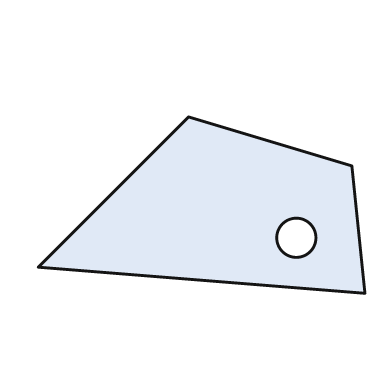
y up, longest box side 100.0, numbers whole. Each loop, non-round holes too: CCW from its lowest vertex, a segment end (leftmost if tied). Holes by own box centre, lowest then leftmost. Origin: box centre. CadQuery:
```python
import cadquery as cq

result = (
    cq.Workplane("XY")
    .moveTo(50.0, -27.0)
    .lineTo(46.0, 12.0)
    .lineTo(-4.0, 27.0)
    .lineTo(-50.0, -19.0)
    .close()
    .moveTo(29.0, -10.0)
    .circle(6.0)
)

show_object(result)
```